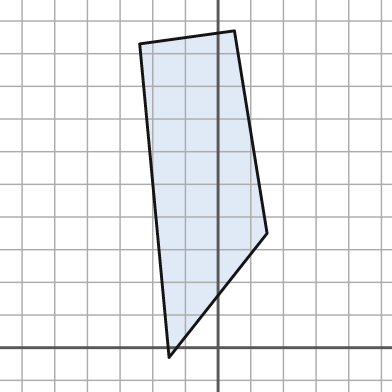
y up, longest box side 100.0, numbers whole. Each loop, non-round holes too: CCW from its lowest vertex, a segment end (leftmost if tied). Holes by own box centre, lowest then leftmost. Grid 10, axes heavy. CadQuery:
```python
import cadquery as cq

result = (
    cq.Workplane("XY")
    .moveTo(-15.0, -3.0)
    .lineTo(15.0, 35.0)
    .lineTo(5.0, 97.0)
    .lineTo(-24.0, 93.0)
    .close()
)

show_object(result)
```